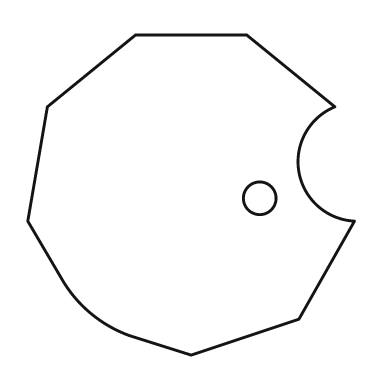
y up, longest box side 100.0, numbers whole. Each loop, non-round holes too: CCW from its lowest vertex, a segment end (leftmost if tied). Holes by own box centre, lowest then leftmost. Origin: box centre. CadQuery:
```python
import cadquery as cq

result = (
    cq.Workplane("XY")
    .moveTo(0.0, -49.0)
    .lineTo(33.0, -38.0)
    .lineTo(50.0, -8.0)
    .threePointArc((33.0, 7.0), (44.0, 27.0))
    .lineTo(17.0, 49.0)
    .lineTo(-17.0, 49.0)
    .lineTo(-44.0, 27.0)
    .lineTo(-50.0, -8.0)
    .lineTo(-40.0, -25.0)
    .threePointArc((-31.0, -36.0), (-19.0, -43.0))
    .close()
    .moveTo(21.0, -1.0)
    .circle(5.0)
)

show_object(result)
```